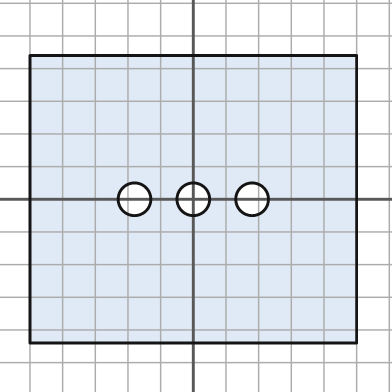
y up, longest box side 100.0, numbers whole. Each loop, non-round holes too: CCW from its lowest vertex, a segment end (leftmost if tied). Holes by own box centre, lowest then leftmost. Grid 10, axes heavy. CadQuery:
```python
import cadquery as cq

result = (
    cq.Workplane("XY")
    .moveTo(-50.0, -44.0)
    .lineTo(50.0, -44.0)
    .lineTo(50.0, 44.0)
    .lineTo(-50.0, 44.0)
    .close()
    .moveTo(-18.0, 0.0)
    .circle(5.0)
    .moveTo(0.0, 0.0)
    .circle(5.0)
    .moveTo(18.0, 0.0)
    .circle(5.0)
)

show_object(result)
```